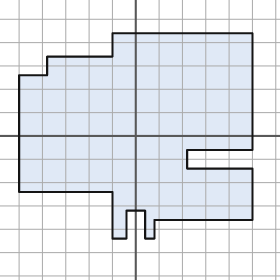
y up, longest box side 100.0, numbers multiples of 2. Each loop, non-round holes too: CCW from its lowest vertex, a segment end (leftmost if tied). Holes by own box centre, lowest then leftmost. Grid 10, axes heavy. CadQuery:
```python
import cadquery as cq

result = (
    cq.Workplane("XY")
    .moveTo(-10.0, -44.0)
    .lineTo(-4.0, -44.0)
    .lineTo(-4.0, -32.0)
    .lineTo(4.0, -32.0)
    .lineTo(4.0, -44.0)
    .lineTo(8.0, -44.0)
    .lineTo(8.0, -36.0)
    .lineTo(50.0, -36.0)
    .lineTo(50.0, -14.0)
    .lineTo(22.0, -14.0)
    .lineTo(22.0, -6.0)
    .lineTo(50.0, -6.0)
    .lineTo(50.0, 44.0)
    .lineTo(-10.0, 44.0)
    .lineTo(-10.0, 34.0)
    .lineTo(-38.0, 34.0)
    .lineTo(-38.0, 26.0)
    .lineTo(-50.0, 26.0)
    .lineTo(-50.0, -24.0)
    .lineTo(-10.0, -24.0)
    .close()
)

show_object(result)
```